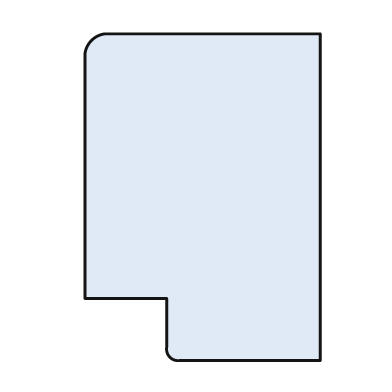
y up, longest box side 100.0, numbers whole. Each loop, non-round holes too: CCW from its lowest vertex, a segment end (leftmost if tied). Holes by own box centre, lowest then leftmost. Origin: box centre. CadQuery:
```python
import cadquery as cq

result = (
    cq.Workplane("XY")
    .moveTo(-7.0, -50.0)
    .lineTo(36.0, -50.0)
    .lineTo(36.0, 50.0)
    .lineTo(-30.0, 50.0)
    .threePointArc((-34.0, 48.0), (-36.0, 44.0))
    .lineTo(-36.0, -31.0)
    .lineTo(-11.0, -31.0)
    .lineTo(-11.0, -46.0)
    .threePointArc((-10.0, -49.0), (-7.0, -50.0))
    .close()
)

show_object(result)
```